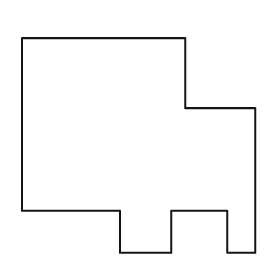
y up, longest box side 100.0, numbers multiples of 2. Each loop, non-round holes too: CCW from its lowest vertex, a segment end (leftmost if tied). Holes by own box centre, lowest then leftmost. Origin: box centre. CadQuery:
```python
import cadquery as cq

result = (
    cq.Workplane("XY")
    .moveTo(-8.0, -46.0)
    .lineTo(14.0, -46.0)
    .lineTo(14.0, -28.0)
    .lineTo(38.0, -28.0)
    .lineTo(38.0, -46.0)
    .lineTo(50.0, -46.0)
    .lineTo(50.0, 16.0)
    .lineTo(20.0, 16.0)
    .lineTo(20.0, 46.0)
    .lineTo(-50.0, 46.0)
    .lineTo(-50.0, -28.0)
    .lineTo(-8.0, -28.0)
    .close()
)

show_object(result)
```